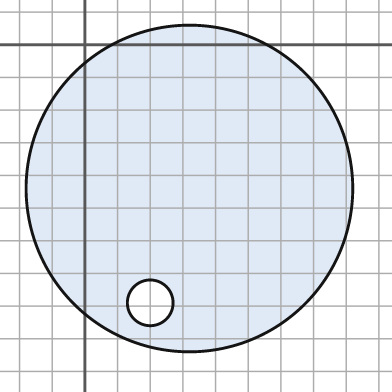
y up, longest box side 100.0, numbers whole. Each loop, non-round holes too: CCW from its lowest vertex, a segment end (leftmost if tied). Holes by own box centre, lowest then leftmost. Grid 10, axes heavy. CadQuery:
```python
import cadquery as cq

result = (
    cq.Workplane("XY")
    .moveTo(32.0, -44.0)
    .circle(50.0)
    .moveTo(20.0, -79.0)
    .circle(7.0)
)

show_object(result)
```